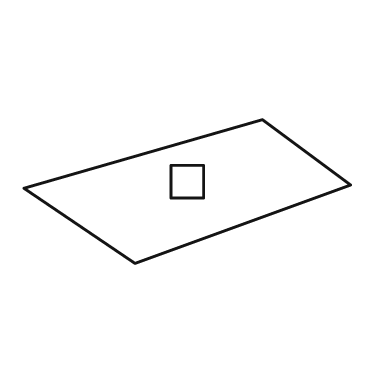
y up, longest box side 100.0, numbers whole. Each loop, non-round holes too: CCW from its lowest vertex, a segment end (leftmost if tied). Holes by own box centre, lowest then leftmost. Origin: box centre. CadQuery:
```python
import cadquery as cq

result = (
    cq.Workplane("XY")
    .moveTo(-16.0, -22.0)
    .lineTo(50.0, 2.0)
    .lineTo(23.0, 22.0)
    .lineTo(-50.0, 1.0)
    .close()
    .moveTo(-5.0, -2.0)
    .lineTo(5.0, -2.0)
    .lineTo(5.0, 8.0)
    .lineTo(-5.0, 8.0)
    .close()
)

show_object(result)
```